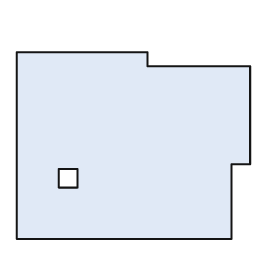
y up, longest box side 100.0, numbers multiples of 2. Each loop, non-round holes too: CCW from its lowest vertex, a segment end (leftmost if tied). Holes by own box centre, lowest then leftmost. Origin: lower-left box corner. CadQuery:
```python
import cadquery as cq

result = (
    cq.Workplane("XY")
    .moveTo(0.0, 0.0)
    .lineTo(92.0, 0.0)
    .lineTo(92.0, 32.0)
    .lineTo(100.0, 32.0)
    .lineTo(100.0, 74.0)
    .lineTo(56.0, 74.0)
    .lineTo(56.0, 80.0)
    .lineTo(0.0, 80.0)
    .close()
    .moveTo(18.0, 22.0)
    .lineTo(26.0, 22.0)
    .lineTo(26.0, 30.0)
    .lineTo(18.0, 30.0)
    .close()
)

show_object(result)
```